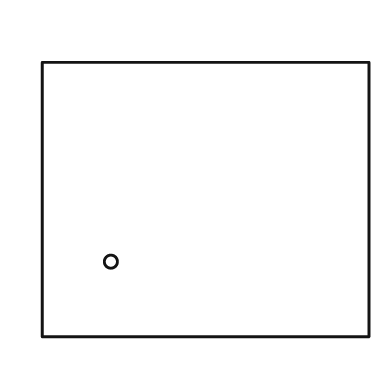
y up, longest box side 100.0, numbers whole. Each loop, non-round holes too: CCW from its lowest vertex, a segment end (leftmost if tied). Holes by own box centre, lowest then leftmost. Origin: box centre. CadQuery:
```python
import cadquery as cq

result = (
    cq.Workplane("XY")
    .moveTo(-50.0, -42.0)
    .lineTo(50.0, -42.0)
    .lineTo(50.0, 42.0)
    .lineTo(-50.0, 42.0)
    .close()
    .moveTo(-29.0, -19.0)
    .circle(2.0)
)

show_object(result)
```